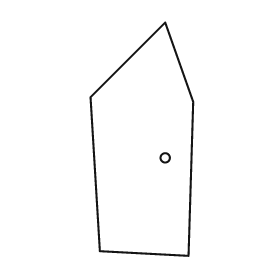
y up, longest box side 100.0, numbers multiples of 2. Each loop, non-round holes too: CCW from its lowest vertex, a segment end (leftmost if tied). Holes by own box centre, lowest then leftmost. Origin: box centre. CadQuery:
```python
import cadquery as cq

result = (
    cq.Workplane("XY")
    .moveTo(20.0, -50.0)
    .lineTo(22.0, 16.0)
    .lineTo(10.0, 50.0)
    .lineTo(-22.0, 18.0)
    .lineTo(-18.0, -48.0)
    .close()
    .moveTo(10.0, -8.0)
    .circle(2.0)
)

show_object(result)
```